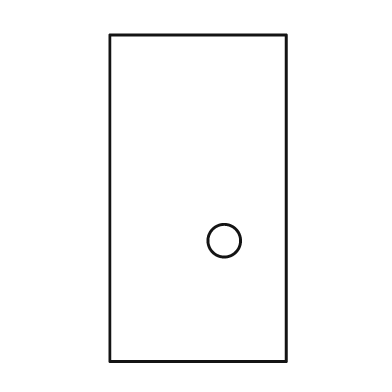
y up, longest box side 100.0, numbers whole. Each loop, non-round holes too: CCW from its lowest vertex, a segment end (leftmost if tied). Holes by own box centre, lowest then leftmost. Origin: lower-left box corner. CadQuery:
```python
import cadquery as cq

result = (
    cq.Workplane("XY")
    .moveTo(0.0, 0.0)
    .lineTo(54.0, 0.0)
    .lineTo(54.0, 100.0)
    .lineTo(0.0, 100.0)
    .close()
    .moveTo(35.0, 37.0)
    .circle(5.0)
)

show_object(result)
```